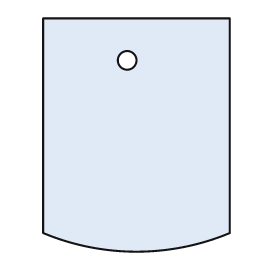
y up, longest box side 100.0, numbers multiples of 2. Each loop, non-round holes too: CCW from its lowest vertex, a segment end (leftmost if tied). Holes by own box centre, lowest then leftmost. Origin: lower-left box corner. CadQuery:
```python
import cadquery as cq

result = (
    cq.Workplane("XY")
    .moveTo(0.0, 8.0)
    .threePointArc((40.0, 0.0), (80.0, 8.0))
    .lineTo(80.0, 100.0)
    .lineTo(0.0, 100.0)
    .close()
    .moveTo(36.0, 82.0)
    .circle(4.0)
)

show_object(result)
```